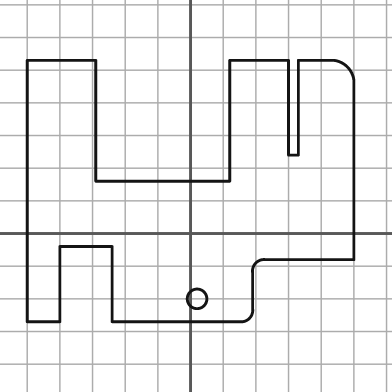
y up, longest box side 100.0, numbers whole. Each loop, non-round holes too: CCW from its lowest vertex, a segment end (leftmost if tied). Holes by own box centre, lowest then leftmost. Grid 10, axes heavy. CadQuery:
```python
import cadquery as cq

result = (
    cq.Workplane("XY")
    .moveTo(-50.0, -27.0)
    .lineTo(-40.0, -27.0)
    .lineTo(-40.0, -4.0)
    .lineTo(-24.0, -4.0)
    .lineTo(-24.0, -27.0)
    .lineTo(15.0, -27.0)
    .threePointArc((18.0, -26.0), (19.0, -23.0))
    .lineTo(19.0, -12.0)
    .threePointArc((20.0, -9.0), (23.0, -8.0))
    .lineTo(50.0, -8.0)
    .lineTo(50.0, 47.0)
    .threePointArc((48.0, 51.0), (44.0, 53.0))
    .lineTo(33.0, 53.0)
    .lineTo(33.0, 24.0)
    .lineTo(30.0, 24.0)
    .lineTo(30.0, 53.0)
    .lineTo(12.0, 53.0)
    .lineTo(12.0, 16.0)
    .lineTo(-29.0, 16.0)
    .lineTo(-29.0, 53.0)
    .lineTo(-50.0, 53.0)
    .close()
    .moveTo(2.0, -20.0)
    .circle(3.0)
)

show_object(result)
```